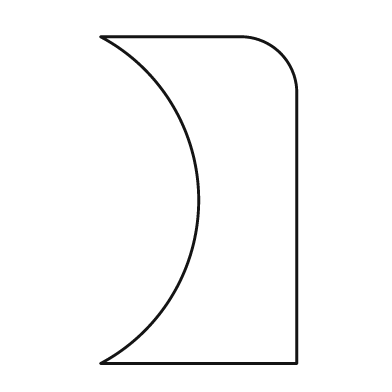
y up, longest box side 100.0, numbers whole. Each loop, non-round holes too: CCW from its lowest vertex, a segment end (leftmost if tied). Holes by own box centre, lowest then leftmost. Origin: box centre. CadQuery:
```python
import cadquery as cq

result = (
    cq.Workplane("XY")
    .moveTo(-30.0, -50.0)
    .lineTo(30.0, -50.0)
    .lineTo(30.0, 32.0)
    .threePointArc((25.0, 45.0), (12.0, 50.0))
    .lineTo(-30.0, 50.0)
    .threePointArc((0.0, 0.0), (-30.0, -50.0))
    .close()
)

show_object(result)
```